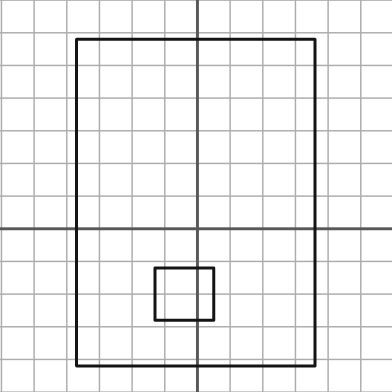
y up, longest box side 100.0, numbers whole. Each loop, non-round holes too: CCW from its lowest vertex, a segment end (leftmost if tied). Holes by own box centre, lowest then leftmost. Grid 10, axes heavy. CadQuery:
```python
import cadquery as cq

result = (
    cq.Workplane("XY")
    .moveTo(-37.0, -42.0)
    .lineTo(36.0, -42.0)
    .lineTo(36.0, 58.0)
    .lineTo(-37.0, 58.0)
    .close()
    .moveTo(-13.0, -28.0)
    .lineTo(5.0, -28.0)
    .lineTo(5.0, -12.0)
    .lineTo(-13.0, -12.0)
    .close()
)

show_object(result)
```